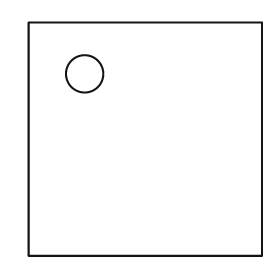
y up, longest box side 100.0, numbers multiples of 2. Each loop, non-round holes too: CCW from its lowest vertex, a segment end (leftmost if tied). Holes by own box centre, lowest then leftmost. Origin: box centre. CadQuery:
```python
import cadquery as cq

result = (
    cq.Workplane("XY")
    .moveTo(-50.0, -50.0)
    .lineTo(50.0, -50.0)
    .lineTo(50.0, 50.0)
    .lineTo(-50.0, 50.0)
    .close()
    .moveTo(-26.0, 28.0)
    .circle(8.0)
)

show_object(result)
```